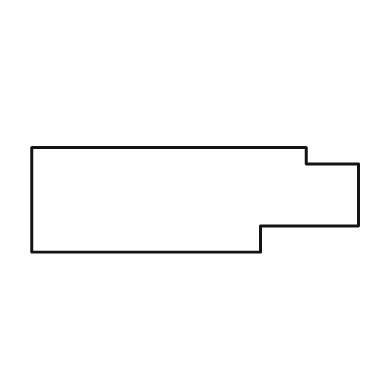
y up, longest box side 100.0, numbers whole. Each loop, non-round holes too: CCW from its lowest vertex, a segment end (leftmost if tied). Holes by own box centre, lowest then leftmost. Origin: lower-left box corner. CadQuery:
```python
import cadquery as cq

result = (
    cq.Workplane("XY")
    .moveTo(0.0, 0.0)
    .lineTo(70.0, 0.0)
    .lineTo(70.0, 8.0)
    .lineTo(100.0, 8.0)
    .lineTo(100.0, 27.0)
    .lineTo(84.0, 27.0)
    .lineTo(84.0, 32.0)
    .lineTo(0.0, 32.0)
    .close()
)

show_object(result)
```